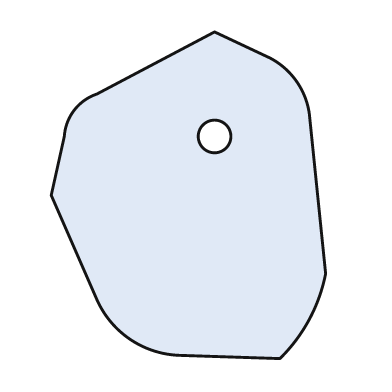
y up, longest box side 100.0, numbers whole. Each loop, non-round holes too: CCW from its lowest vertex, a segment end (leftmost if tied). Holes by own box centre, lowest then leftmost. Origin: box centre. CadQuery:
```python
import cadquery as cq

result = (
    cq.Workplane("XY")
    .moveTo(28.0, -50.0)
    .threePointArc((37.0, -38.0), (42.0, -24.0))
    .lineTo(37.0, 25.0)
    .threePointArc((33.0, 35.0), (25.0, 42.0))
    .lineTo(8.0, 50.0)
    .lineTo(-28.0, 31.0)
    .threePointArc((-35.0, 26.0), (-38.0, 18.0))
    .lineTo(-42.0, 0.0)
    .lineTo(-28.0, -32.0)
    .threePointArc((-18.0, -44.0), (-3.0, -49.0))
    .close()
    .moveTo(8.0, 18.0)
    .circle(5.0)
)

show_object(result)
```